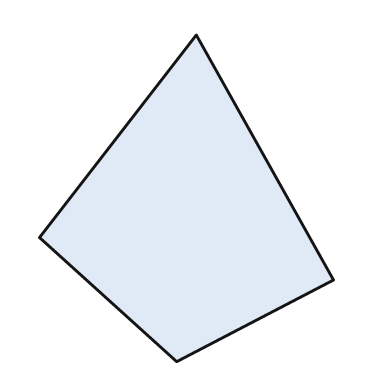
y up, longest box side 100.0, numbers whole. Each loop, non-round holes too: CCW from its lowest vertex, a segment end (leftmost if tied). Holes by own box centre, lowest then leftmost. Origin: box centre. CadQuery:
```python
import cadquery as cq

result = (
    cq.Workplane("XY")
    .moveTo(-3.0, -50.0)
    .lineTo(45.0, -25.0)
    .lineTo(3.0, 50.0)
    .lineTo(-45.0, -12.0)
    .close()
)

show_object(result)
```